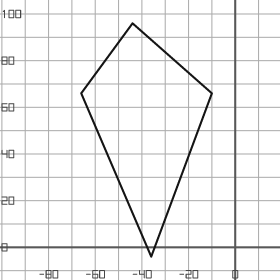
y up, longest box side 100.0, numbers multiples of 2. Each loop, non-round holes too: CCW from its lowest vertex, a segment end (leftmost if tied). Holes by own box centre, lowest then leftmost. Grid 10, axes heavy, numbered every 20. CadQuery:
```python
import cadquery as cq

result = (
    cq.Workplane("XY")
    .moveTo(-36.0, -4.0)
    .lineTo(-10.0, 66.0)
    .lineTo(-44.0, 96.0)
    .lineTo(-66.0, 66.0)
    .close()
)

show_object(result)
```